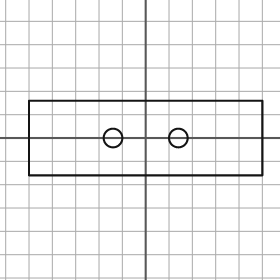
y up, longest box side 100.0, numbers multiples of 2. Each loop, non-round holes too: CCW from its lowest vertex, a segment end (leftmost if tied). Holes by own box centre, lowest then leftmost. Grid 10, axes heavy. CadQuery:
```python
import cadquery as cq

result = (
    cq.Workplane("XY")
    .moveTo(-50.0, -16.0)
    .lineTo(50.0, -16.0)
    .lineTo(50.0, 16.0)
    .lineTo(-50.0, 16.0)
    .close()
    .moveTo(-14.0, 0.0)
    .circle(4.0)
    .moveTo(14.0, 0.0)
    .circle(4.0)
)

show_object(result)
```